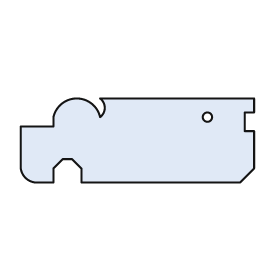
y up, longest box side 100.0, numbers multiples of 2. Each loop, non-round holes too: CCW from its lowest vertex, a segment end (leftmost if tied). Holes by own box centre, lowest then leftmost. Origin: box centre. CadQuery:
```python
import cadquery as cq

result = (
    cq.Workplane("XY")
    .moveTo(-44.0, -18.0)
    .lineTo(-36.0, -18.0)
    .lineTo(-36.0, -12.0)
    .lineTo(-32.0, -8.0)
    .lineTo(-28.0, -8.0)
    .lineTo(-24.0, -12.0)
    .lineTo(-24.0, -18.0)
    .lineTo(44.0, -18.0)
    .lineTo(50.0, -12.0)
    .lineTo(50.0, 4.0)
    .lineTo(46.0, 4.0)
    .lineTo(46.0, 12.0)
    .lineTo(50.0, 12.0)
    .lineTo(50.0, 18.0)
    .lineTo(-16.0, 18.0)
    .threePointArc((-14.0, 14.0), (-16.0, 10.0))
    .threePointArc((-26.0, 18.0), (-36.0, 10.0))
    .lineTo(-36.0, 6.0)
    .lineTo(-50.0, 6.0)
    .lineTo(-50.0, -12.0)
    .threePointArc((-48.0, -16.0), (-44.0, -18.0))
    .close()
    .moveTo(30.0, 10.0)
    .circle(2.0)
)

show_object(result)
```